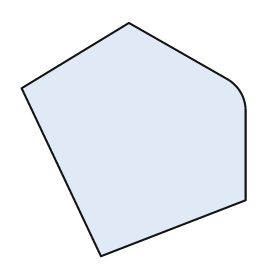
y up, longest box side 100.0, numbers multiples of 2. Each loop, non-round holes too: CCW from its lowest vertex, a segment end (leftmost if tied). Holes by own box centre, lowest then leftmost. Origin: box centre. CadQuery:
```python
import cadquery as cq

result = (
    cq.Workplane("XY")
    .moveTo(-14.0, -50.0)
    .lineTo(48.0, -26.0)
    .lineTo(48.0, 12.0)
    .threePointArc((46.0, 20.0), (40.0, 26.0))
    .lineTo(-2.0, 50.0)
    .lineTo(-48.0, 22.0)
    .close()
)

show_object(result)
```